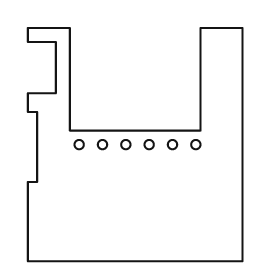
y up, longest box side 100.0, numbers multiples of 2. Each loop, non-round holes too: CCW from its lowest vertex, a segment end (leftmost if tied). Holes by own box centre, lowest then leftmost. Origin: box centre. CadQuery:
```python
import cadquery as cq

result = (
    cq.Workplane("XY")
    .moveTo(-46.0, -50.0)
    .lineTo(46.0, -50.0)
    .lineTo(46.0, 50.0)
    .lineTo(28.0, 50.0)
    .lineTo(28.0, 6.0)
    .lineTo(-28.0, 6.0)
    .lineTo(-28.0, 50.0)
    .lineTo(-46.0, 50.0)
    .lineTo(-46.0, 44.0)
    .lineTo(-34.0, 44.0)
    .lineTo(-34.0, 22.0)
    .lineTo(-46.0, 22.0)
    .lineTo(-46.0, 14.0)
    .lineTo(-42.0, 14.0)
    .lineTo(-42.0, -16.0)
    .lineTo(-46.0, -16.0)
    .close()
    .moveTo(-24.0, 0.0)
    .circle(2.0)
    .moveTo(-14.0, 0.0)
    .circle(2.0)
    .moveTo(-4.0, 0.0)
    .circle(2.0)
    .moveTo(6.0, 0.0)
    .circle(2.0)
    .moveTo(16.0, 0.0)
    .circle(2.0)
    .moveTo(26.0, 0.0)
    .circle(2.0)
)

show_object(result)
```